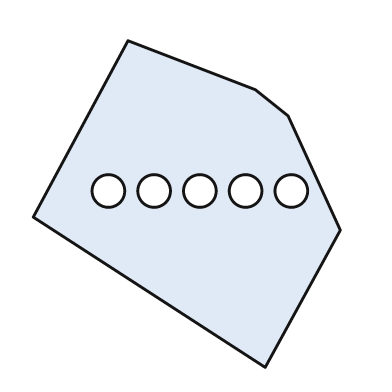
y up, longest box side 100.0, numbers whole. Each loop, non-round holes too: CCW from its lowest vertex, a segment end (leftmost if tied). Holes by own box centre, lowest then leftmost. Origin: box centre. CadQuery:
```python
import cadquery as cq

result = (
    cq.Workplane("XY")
    .moveTo(24.0, -50.0)
    .lineTo(47.0, -8.0)
    .lineTo(31.0, 27.0)
    .lineTo(21.0, 35.0)
    .lineTo(-18.0, 50.0)
    .lineTo(-47.0, -4.0)
    .close()
    .moveTo(-24.0, 4.0)
    .circle(5.0)
    .moveTo(-10.0, 4.0)
    .circle(5.0)
    .moveTo(4.0, 4.0)
    .circle(5.0)
    .moveTo(18.0, 4.0)
    .circle(5.0)
    .moveTo(32.0, 4.0)
    .circle(5.0)
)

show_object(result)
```